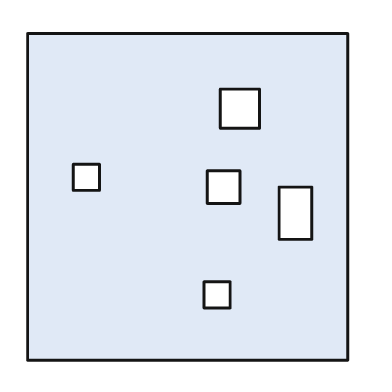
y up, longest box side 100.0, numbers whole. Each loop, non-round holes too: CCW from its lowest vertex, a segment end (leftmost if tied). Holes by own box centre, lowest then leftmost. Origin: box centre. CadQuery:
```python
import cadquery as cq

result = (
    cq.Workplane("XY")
    .moveTo(-49.0, -50.0)
    .lineTo(49.0, -50.0)
    .lineTo(49.0, 50.0)
    .lineTo(-49.0, 50.0)
    .close()
    .moveTo(5.0, -34.0)
    .lineTo(13.0, -34.0)
    .lineTo(13.0, -26.0)
    .lineTo(5.0, -26.0)
    .close()
    .moveTo(28.0, -13.0)
    .lineTo(38.0, -13.0)
    .lineTo(38.0, 3.0)
    .lineTo(28.0, 3.0)
    .close()
    .moveTo(6.0, -2.0)
    .lineTo(16.0, -2.0)
    .lineTo(16.0, 8.0)
    .lineTo(6.0, 8.0)
    .close()
    .moveTo(-35.0, 2.0)
    .lineTo(-27.0, 2.0)
    .lineTo(-27.0, 10.0)
    .lineTo(-35.0, 10.0)
    .close()
    .moveTo(10.0, 21.0)
    .lineTo(22.0, 21.0)
    .lineTo(22.0, 33.0)
    .lineTo(10.0, 33.0)
    .close()
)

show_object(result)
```